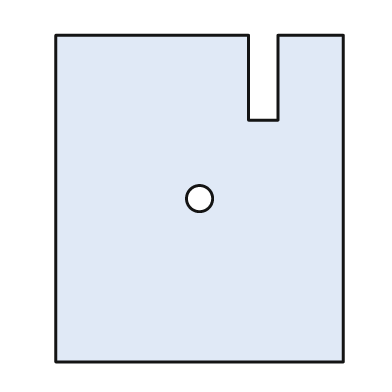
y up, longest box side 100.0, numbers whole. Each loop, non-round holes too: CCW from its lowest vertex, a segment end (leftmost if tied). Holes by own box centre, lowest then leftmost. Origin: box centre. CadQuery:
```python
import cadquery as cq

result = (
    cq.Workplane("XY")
    .moveTo(-44.0, -50.0)
    .lineTo(44.0, -50.0)
    .lineTo(44.0, 50.0)
    .lineTo(24.0, 50.0)
    .lineTo(24.0, 24.0)
    .lineTo(15.0, 24.0)
    .lineTo(15.0, 50.0)
    .lineTo(-44.0, 50.0)
    .close()
    .moveTo(0.0, 0.0)
    .circle(4.0)
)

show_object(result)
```